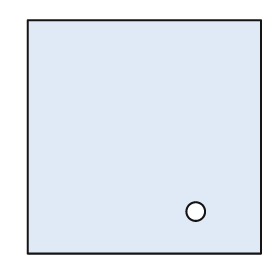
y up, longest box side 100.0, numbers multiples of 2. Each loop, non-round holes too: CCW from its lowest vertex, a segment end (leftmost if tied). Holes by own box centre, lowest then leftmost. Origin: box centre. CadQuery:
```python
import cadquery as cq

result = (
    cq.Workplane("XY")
    .moveTo(-50.0, -50.0)
    .lineTo(50.0, -50.0)
    .lineTo(50.0, 50.0)
    .lineTo(-50.0, 50.0)
    .close()
    .moveTo(22.0, -32.0)
    .circle(4.0)
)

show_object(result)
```